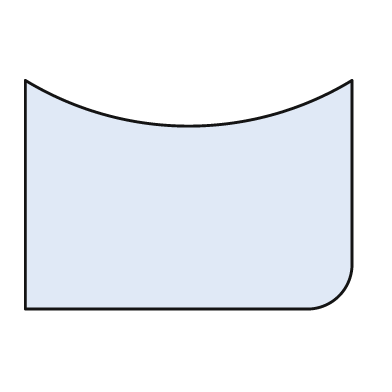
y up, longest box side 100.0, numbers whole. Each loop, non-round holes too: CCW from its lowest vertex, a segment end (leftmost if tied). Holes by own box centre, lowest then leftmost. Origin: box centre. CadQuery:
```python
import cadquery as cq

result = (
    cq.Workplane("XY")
    .moveTo(-50.0, -35.0)
    .lineTo(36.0, -35.0)
    .threePointArc((46.0, -31.0), (50.0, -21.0))
    .lineTo(50.0, 35.0)
    .threePointArc((0.0, 21.0), (-50.0, 35.0))
    .close()
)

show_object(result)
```